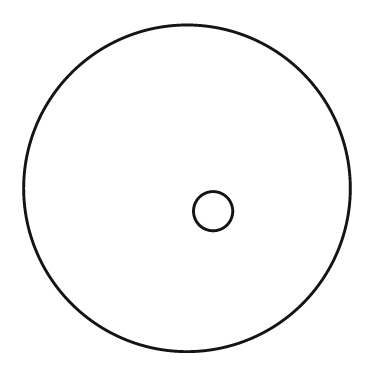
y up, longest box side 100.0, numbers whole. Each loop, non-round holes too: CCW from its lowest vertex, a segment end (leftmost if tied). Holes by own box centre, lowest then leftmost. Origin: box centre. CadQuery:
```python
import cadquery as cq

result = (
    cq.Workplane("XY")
    .moveTo(0.0, 0.0)
    .circle(50.0)
    .moveTo(8.0, -7.0)
    .circle(6.0)
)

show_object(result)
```